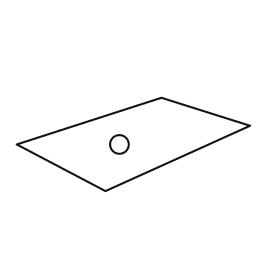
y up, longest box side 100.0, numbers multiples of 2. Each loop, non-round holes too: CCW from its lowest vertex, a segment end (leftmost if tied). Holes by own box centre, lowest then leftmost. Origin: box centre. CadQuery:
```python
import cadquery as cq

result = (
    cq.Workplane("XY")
    .moveTo(-12.0, -20.0)
    .lineTo(50.0, 8.0)
    .lineTo(12.0, 20.0)
    .lineTo(-50.0, 0.0)
    .close()
    .moveTo(-6.0, 0.0)
    .circle(4.0)
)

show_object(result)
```